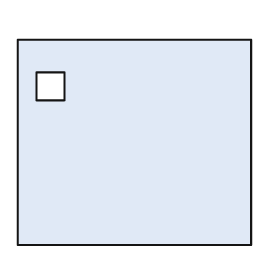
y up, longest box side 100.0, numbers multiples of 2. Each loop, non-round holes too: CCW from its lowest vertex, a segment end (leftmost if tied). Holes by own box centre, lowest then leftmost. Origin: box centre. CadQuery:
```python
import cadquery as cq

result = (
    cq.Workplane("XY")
    .moveTo(-50.0, -44.0)
    .lineTo(50.0, -44.0)
    .lineTo(50.0, 44.0)
    .lineTo(-50.0, 44.0)
    .close()
    .moveTo(-42.0, 18.0)
    .lineTo(-30.0, 18.0)
    .lineTo(-30.0, 30.0)
    .lineTo(-42.0, 30.0)
    .close()
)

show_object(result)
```